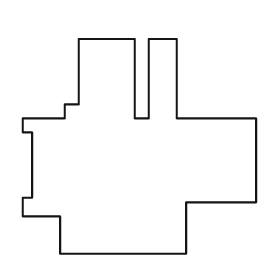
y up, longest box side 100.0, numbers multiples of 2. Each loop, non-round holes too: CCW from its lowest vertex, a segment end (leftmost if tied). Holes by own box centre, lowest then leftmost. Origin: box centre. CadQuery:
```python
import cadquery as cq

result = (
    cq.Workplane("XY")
    .moveTo(-34.0, -46.0)
    .lineTo(20.0, -46.0)
    .lineTo(20.0, -24.0)
    .lineTo(50.0, -24.0)
    .lineTo(50.0, 12.0)
    .lineTo(16.0, 12.0)
    .lineTo(16.0, 46.0)
    .lineTo(4.0, 46.0)
    .lineTo(4.0, 12.0)
    .lineTo(-2.0, 12.0)
    .lineTo(-2.0, 46.0)
    .lineTo(-26.0, 46.0)
    .lineTo(-26.0, 18.0)
    .lineTo(-32.0, 18.0)
    .lineTo(-32.0, 12.0)
    .lineTo(-50.0, 12.0)
    .lineTo(-50.0, 6.0)
    .lineTo(-46.0, 6.0)
    .lineTo(-46.0, -22.0)
    .lineTo(-50.0, -22.0)
    .lineTo(-50.0, -30.0)
    .lineTo(-34.0, -30.0)
    .close()
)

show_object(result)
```